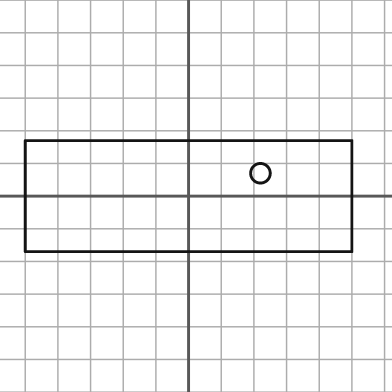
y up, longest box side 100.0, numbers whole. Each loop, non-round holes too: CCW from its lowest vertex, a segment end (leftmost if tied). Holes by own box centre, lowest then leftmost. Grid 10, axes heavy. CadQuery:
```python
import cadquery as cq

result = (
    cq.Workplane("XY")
    .moveTo(-50.0, -17.0)
    .lineTo(50.0, -17.0)
    .lineTo(50.0, 17.0)
    .lineTo(-50.0, 17.0)
    .close()
    .moveTo(22.0, 7.0)
    .circle(3.0)
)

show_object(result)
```